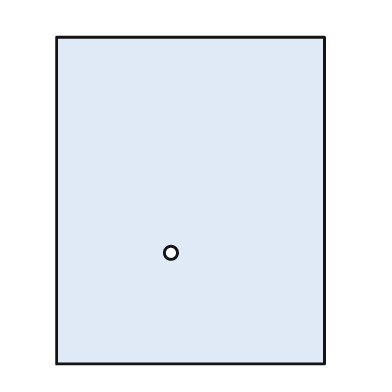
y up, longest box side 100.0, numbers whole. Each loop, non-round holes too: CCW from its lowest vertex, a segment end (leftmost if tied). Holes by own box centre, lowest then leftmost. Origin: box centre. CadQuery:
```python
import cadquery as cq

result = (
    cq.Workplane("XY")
    .moveTo(-41.0, -50.0)
    .lineTo(41.0, -50.0)
    .lineTo(41.0, 50.0)
    .lineTo(-41.0, 50.0)
    .close()
    .moveTo(-6.0, -16.0)
    .circle(2.0)
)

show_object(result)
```